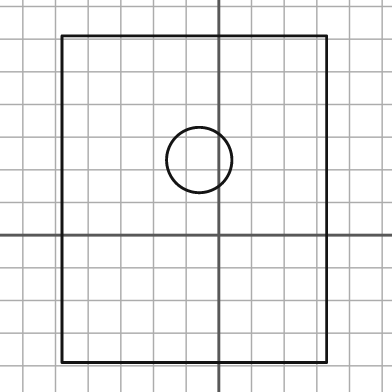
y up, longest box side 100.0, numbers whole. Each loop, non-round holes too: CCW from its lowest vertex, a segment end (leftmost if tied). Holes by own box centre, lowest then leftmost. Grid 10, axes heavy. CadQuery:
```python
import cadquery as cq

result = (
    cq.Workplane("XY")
    .moveTo(-48.0, -39.0)
    .lineTo(33.0, -39.0)
    .lineTo(33.0, 61.0)
    .lineTo(-48.0, 61.0)
    .close()
    .moveTo(-6.0, 23.0)
    .circle(10.0)
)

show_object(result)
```